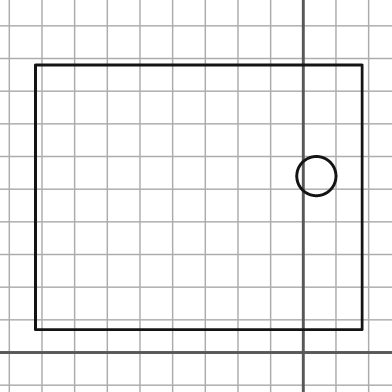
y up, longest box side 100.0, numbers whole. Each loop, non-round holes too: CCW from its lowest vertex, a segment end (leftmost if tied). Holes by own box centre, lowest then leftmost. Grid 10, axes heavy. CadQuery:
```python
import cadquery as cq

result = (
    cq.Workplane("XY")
    .moveTo(-82.0, 7.0)
    .lineTo(18.0, 7.0)
    .lineTo(18.0, 88.0)
    .lineTo(-82.0, 88.0)
    .close()
    .moveTo(4.0, 54.0)
    .circle(6.0)
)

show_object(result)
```